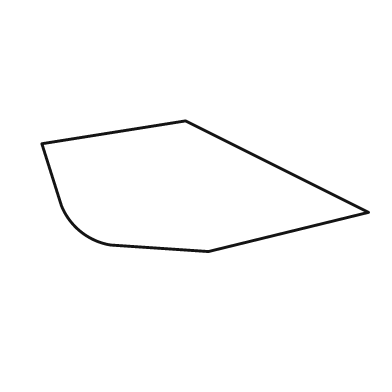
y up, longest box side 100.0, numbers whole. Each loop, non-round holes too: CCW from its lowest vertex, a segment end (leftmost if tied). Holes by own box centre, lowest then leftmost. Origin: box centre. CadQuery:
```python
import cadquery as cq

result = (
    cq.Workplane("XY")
    .moveTo(1.0, -20.0)
    .lineTo(50.0, -8.0)
    .lineTo(-6.0, 20.0)
    .lineTo(-50.0, 13.0)
    .lineTo(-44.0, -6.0)
    .threePointArc((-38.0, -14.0), (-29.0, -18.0))
    .close()
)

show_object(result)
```